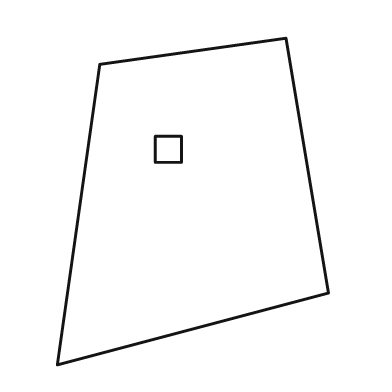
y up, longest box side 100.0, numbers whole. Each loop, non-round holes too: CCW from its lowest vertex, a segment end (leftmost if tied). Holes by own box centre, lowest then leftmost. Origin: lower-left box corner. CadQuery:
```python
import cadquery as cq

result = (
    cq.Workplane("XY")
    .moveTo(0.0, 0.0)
    .lineTo(83.0, 22.0)
    .lineTo(70.0, 100.0)
    .lineTo(13.0, 92.0)
    .close()
    .moveTo(30.0, 62.0)
    .lineTo(38.0, 62.0)
    .lineTo(38.0, 70.0)
    .lineTo(30.0, 70.0)
    .close()
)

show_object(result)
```